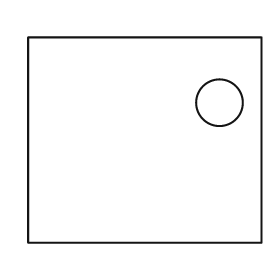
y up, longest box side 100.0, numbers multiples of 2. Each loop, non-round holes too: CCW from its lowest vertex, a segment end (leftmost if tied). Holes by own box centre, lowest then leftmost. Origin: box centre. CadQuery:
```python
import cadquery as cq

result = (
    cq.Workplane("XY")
    .moveTo(-50.0, -44.0)
    .lineTo(50.0, -44.0)
    .lineTo(50.0, 44.0)
    .lineTo(-50.0, 44.0)
    .close()
    .moveTo(32.0, 16.0)
    .circle(10.0)
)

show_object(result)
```